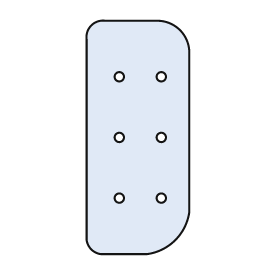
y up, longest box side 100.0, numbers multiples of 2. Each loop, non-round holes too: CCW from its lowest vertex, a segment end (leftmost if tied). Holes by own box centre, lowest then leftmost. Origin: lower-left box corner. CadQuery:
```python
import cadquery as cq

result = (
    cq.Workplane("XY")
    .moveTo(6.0, 0.0)
    .lineTo(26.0, 0.0)
    .threePointArc((38.0, 6.0), (44.0, 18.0))
    .lineTo(44.0, 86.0)
    .threePointArc((40.0, 96.0), (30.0, 100.0))
    .lineTo(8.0, 100.0)
    .threePointArc((2.0, 98.0), (0.0, 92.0))
    .lineTo(0.0, 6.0)
    .threePointArc((2.0, 2.0), (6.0, 0.0))
    .close()
    .moveTo(14.0, 24.0)
    .circle(2.0)
    .moveTo(32.0, 24.0)
    .circle(2.0)
    .moveTo(14.0, 50.0)
    .circle(2.0)
    .moveTo(32.0, 50.0)
    .circle(2.0)
    .moveTo(14.0, 76.0)
    .circle(2.0)
    .moveTo(32.0, 76.0)
    .circle(2.0)
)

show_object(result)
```